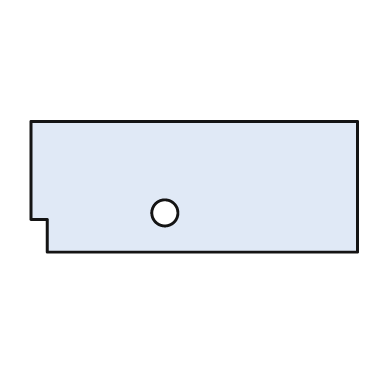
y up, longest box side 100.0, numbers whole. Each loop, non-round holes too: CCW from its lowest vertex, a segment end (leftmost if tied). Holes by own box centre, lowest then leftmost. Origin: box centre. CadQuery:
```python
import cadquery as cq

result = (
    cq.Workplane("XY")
    .moveTo(-45.0, -20.0)
    .lineTo(50.0, -20.0)
    .lineTo(50.0, 20.0)
    .lineTo(-50.0, 20.0)
    .lineTo(-50.0, -10.0)
    .lineTo(-45.0, -10.0)
    .close()
    .moveTo(-9.0, -8.0)
    .circle(4.0)
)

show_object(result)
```